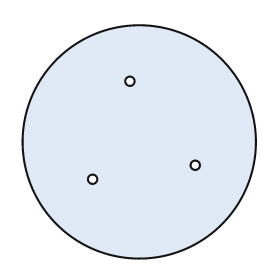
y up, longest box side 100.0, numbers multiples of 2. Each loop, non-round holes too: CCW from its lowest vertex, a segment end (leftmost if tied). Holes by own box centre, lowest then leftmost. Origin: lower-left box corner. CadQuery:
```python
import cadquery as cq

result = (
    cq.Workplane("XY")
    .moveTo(50.0, 50.0)
    .circle(50.0)
    .moveTo(30.0, 34.0)
    .circle(2.0)
    .moveTo(74.0, 40.0)
    .circle(2.0)
    .moveTo(46.0, 76.0)
    .circle(2.0)
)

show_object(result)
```